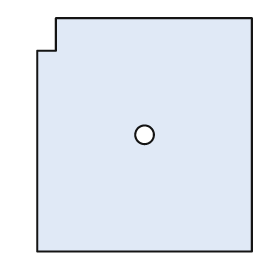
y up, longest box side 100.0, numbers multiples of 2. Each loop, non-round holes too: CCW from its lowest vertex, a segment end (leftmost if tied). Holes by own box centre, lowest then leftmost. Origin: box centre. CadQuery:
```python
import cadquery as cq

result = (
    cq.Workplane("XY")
    .moveTo(-46.0, -50.0)
    .lineTo(46.0, -50.0)
    .lineTo(46.0, 50.0)
    .lineTo(-38.0, 50.0)
    .lineTo(-38.0, 36.0)
    .lineTo(-46.0, 36.0)
    .close()
    .moveTo(0.0, 0.0)
    .circle(4.0)
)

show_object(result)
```